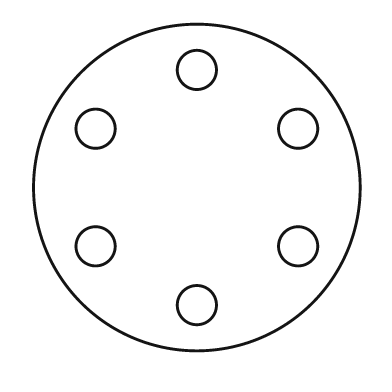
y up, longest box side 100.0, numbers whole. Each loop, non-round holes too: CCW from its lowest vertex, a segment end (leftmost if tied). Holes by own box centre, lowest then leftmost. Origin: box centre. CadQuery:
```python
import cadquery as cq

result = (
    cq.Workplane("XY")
    .moveTo(0.0, 0.0)
    .circle(50.0)
    .moveTo(0.0, -36.0)
    .circle(6.0)
    .moveTo(-31.0, -18.0)
    .circle(6.0)
    .moveTo(31.0, -18.0)
    .circle(6.0)
    .moveTo(-31.0, 18.0)
    .circle(6.0)
    .moveTo(31.0, 18.0)
    .circle(6.0)
    .moveTo(0.0, 36.0)
    .circle(6.0)
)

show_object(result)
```